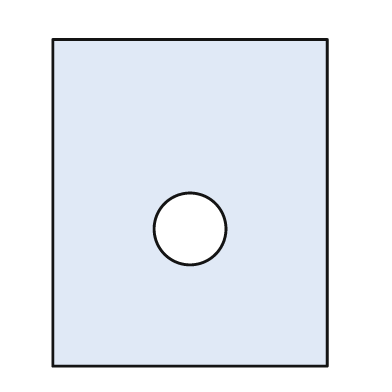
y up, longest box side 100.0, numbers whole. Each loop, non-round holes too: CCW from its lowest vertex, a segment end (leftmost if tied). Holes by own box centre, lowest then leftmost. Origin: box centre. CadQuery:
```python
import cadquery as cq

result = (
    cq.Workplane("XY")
    .moveTo(-42.0, -50.0)
    .lineTo(42.0, -50.0)
    .lineTo(42.0, 50.0)
    .lineTo(-42.0, 50.0)
    .close()
    .moveTo(0.0, -8.0)
    .circle(11.0)
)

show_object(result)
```